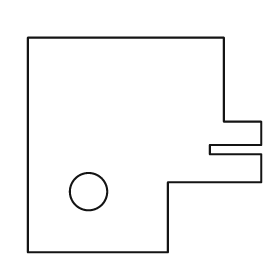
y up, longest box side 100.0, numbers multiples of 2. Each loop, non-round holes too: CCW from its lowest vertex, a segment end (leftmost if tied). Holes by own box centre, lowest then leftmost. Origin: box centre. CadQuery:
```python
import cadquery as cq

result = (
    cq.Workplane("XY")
    .moveTo(-50.0, -46.0)
    .lineTo(10.0, -46.0)
    .lineTo(10.0, -16.0)
    .lineTo(50.0, -16.0)
    .lineTo(50.0, -4.0)
    .lineTo(28.0, -4.0)
    .lineTo(28.0, 0.0)
    .lineTo(50.0, 0.0)
    .lineTo(50.0, 10.0)
    .lineTo(34.0, 10.0)
    .lineTo(34.0, 46.0)
    .lineTo(-50.0, 46.0)
    .close()
    .moveTo(-24.0, -20.0)
    .circle(8.0)
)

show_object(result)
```